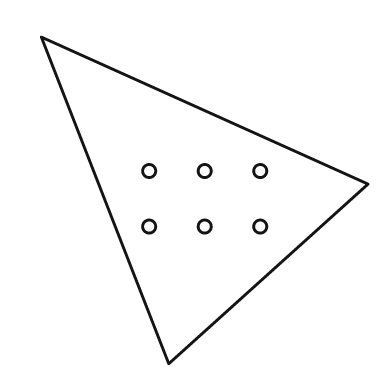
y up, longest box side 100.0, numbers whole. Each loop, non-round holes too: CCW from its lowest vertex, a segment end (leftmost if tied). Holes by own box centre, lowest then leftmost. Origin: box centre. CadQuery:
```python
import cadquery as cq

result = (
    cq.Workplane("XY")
    .moveTo(-11.0, -50.0)
    .lineTo(50.0, 5.0)
    .lineTo(-50.0, 50.0)
    .close()
    .moveTo(-17.0, -8.0)
    .circle(2.0)
    .moveTo(0.0, -8.0)
    .circle(2.0)
    .moveTo(17.0, -8.0)
    .circle(2.0)
    .moveTo(-17.0, 9.0)
    .circle(2.0)
    .moveTo(0.0, 9.0)
    .circle(2.0)
    .moveTo(17.0, 9.0)
    .circle(2.0)
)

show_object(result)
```